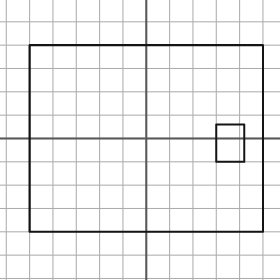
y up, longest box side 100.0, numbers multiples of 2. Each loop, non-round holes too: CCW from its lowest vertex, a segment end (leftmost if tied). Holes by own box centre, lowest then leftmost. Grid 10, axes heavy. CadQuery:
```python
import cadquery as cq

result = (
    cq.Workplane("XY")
    .moveTo(-50.0, -40.0)
    .lineTo(50.0, -40.0)
    .lineTo(50.0, 40.0)
    .lineTo(-50.0, 40.0)
    .close()
    .moveTo(30.0, -10.0)
    .lineTo(42.0, -10.0)
    .lineTo(42.0, 6.0)
    .lineTo(30.0, 6.0)
    .close()
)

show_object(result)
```